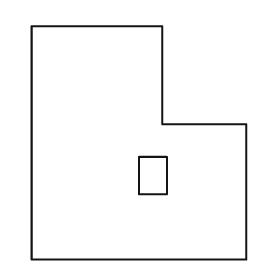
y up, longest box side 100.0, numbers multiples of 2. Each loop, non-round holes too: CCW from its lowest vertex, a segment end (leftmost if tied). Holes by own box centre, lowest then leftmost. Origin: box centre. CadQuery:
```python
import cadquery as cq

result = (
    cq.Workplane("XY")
    .moveTo(-46.0, -50.0)
    .lineTo(46.0, -50.0)
    .lineTo(46.0, 8.0)
    .lineTo(10.0, 8.0)
    .lineTo(10.0, 50.0)
    .lineTo(-46.0, 50.0)
    .close()
    .moveTo(0.0, -22.0)
    .lineTo(12.0, -22.0)
    .lineTo(12.0, -6.0)
    .lineTo(0.0, -6.0)
    .close()
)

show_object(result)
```